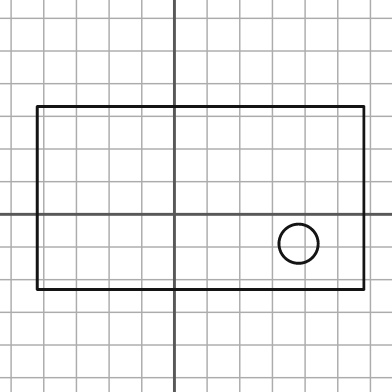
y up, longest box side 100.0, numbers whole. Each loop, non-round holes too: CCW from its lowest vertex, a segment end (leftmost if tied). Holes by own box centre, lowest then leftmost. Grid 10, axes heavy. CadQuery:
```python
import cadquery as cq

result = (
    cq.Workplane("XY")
    .moveTo(-42.0, -23.0)
    .lineTo(58.0, -23.0)
    .lineTo(58.0, 33.0)
    .lineTo(-42.0, 33.0)
    .close()
    .moveTo(38.0, -9.0)
    .circle(6.0)
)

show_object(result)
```